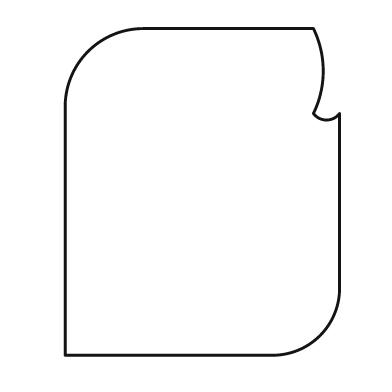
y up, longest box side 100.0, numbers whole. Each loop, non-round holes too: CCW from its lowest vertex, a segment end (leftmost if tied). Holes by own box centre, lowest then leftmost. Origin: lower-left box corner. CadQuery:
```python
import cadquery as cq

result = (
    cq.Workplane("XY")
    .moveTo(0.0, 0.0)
    .lineTo(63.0, 0.0)
    .threePointArc((78.0, 6.0), (84.0, 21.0))
    .lineTo(84.0, 74.0)
    .threePointArc((80.0, 72.0), (76.0, 74.0))
    .threePointArc((79.0, 87.0), (76.0, 100.0))
    .lineTo(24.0, 100.0)
    .threePointArc((7.0, 93.0), (0.0, 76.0))
    .close()
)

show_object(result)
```